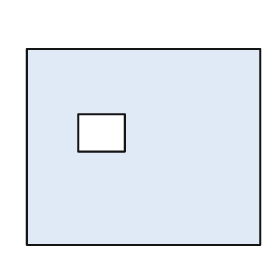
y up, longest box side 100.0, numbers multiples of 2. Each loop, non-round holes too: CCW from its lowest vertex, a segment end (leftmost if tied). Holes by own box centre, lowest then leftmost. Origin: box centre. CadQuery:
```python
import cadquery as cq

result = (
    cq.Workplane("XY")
    .moveTo(-50.0, -42.0)
    .lineTo(50.0, -42.0)
    .lineTo(50.0, 42.0)
    .lineTo(-50.0, 42.0)
    .close()
    .moveTo(-28.0, -2.0)
    .lineTo(-8.0, -2.0)
    .lineTo(-8.0, 14.0)
    .lineTo(-28.0, 14.0)
    .close()
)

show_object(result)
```